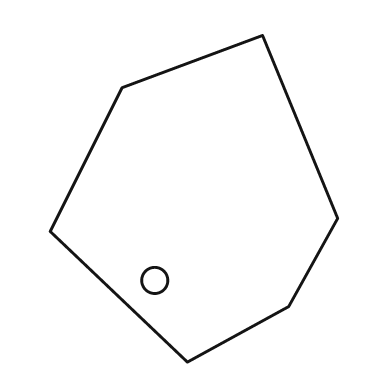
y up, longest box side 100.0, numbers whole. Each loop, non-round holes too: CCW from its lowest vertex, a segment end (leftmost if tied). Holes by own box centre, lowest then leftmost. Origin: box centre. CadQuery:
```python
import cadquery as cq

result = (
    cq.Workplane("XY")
    .moveTo(-2.0, -50.0)
    .lineTo(29.0, -33.0)
    .lineTo(44.0, -6.0)
    .lineTo(21.0, 50.0)
    .lineTo(-22.0, 34.0)
    .lineTo(-44.0, -10.0)
    .close()
    .moveTo(-12.0, -25.0)
    .circle(4.0)
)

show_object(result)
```